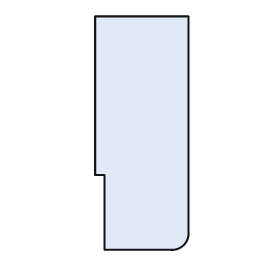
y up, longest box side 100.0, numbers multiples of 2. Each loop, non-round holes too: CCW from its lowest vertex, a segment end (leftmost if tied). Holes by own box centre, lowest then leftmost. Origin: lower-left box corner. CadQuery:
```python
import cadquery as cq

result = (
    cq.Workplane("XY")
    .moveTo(4.0, 0.0)
    .lineTo(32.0, 0.0)
    .threePointArc((38.0, 2.0), (40.0, 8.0))
    .lineTo(40.0, 100.0)
    .lineTo(0.0, 100.0)
    .lineTo(0.0, 32.0)
    .lineTo(4.0, 32.0)
    .close()
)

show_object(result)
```